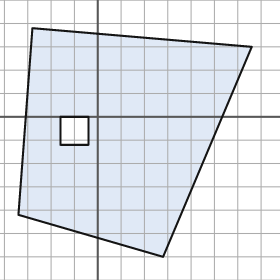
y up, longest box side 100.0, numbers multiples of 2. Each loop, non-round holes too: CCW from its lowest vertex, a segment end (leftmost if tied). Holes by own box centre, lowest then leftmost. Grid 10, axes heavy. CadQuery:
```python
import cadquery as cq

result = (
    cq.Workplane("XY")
    .moveTo(28.0, -60.0)
    .lineTo(66.0, 30.0)
    .lineTo(-28.0, 38.0)
    .lineTo(-34.0, -42.0)
    .close()
    .moveTo(-16.0, -12.0)
    .lineTo(-4.0, -12.0)
    .lineTo(-4.0, 0.0)
    .lineTo(-16.0, 0.0)
    .close()
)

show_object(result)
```